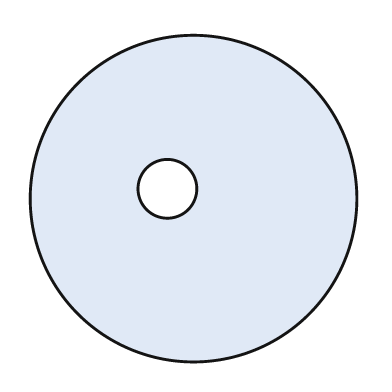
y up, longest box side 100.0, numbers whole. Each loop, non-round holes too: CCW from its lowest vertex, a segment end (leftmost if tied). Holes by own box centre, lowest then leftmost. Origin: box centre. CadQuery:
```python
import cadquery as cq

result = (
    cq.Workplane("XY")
    .moveTo(0.0, 0.0)
    .circle(50.0)
    .moveTo(-8.0, 3.0)
    .circle(9.0)
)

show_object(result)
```